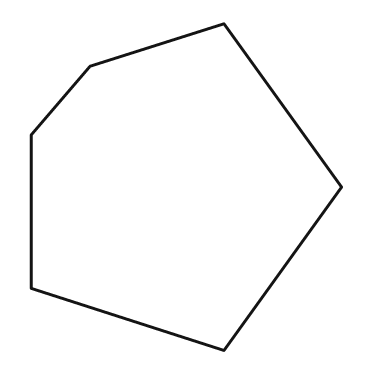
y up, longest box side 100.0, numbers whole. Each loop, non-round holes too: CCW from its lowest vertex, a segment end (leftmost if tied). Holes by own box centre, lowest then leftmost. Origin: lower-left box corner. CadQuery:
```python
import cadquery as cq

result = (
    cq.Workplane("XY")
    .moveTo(59.0, 0.0)
    .lineTo(95.0, 50.0)
    .lineTo(59.0, 100.0)
    .lineTo(18.0, 87.0)
    .lineTo(0.0, 66.0)
    .lineTo(0.0, 19.0)
    .close()
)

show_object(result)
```